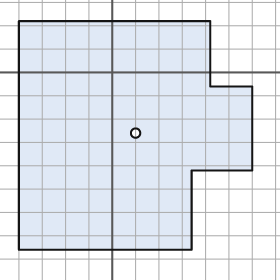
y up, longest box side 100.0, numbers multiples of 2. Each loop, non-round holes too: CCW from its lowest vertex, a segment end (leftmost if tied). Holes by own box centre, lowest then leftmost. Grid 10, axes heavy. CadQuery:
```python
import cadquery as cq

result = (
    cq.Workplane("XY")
    .moveTo(-40.0, -76.0)
    .lineTo(34.0, -76.0)
    .lineTo(34.0, -42.0)
    .lineTo(60.0, -42.0)
    .lineTo(60.0, -6.0)
    .lineTo(42.0, -6.0)
    .lineTo(42.0, 22.0)
    .lineTo(-40.0, 22.0)
    .close()
    .moveTo(10.0, -26.0)
    .circle(2.0)
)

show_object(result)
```